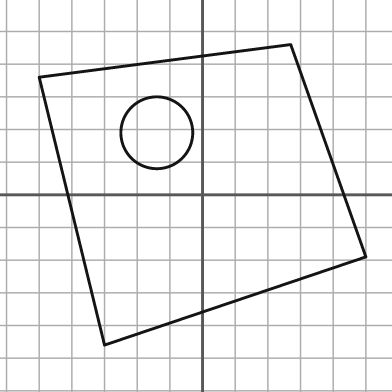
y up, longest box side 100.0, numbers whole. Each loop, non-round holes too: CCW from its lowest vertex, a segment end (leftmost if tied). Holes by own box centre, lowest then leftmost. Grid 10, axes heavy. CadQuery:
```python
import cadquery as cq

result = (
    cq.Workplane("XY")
    .moveTo(-30.0, -46.0)
    .lineTo(50.0, -19.0)
    .lineTo(27.0, 46.0)
    .lineTo(-50.0, 36.0)
    .close()
    .moveTo(-14.0, 19.0)
    .circle(11.0)
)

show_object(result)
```